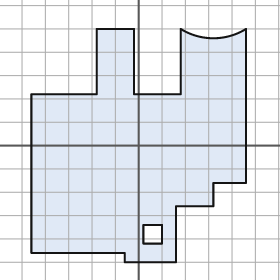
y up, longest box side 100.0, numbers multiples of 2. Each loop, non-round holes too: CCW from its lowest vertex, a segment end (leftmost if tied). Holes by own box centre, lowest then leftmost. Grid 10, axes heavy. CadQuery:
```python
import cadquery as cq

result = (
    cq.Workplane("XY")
    .moveTo(-6.0, -50.0)
    .lineTo(16.0, -50.0)
    .lineTo(16.0, -26.0)
    .lineTo(32.0, -26.0)
    .lineTo(32.0, -16.0)
    .lineTo(46.0, -16.0)
    .lineTo(46.0, 50.0)
    .threePointArc((32.0, 46.0), (18.0, 50.0))
    .lineTo(18.0, 22.0)
    .lineTo(-2.0, 22.0)
    .lineTo(-2.0, 50.0)
    .lineTo(-18.0, 50.0)
    .lineTo(-18.0, 22.0)
    .lineTo(-46.0, 22.0)
    .lineTo(-46.0, -46.0)
    .lineTo(-6.0, -46.0)
    .close()
    .moveTo(2.0, -42.0)
    .lineTo(10.0, -42.0)
    .lineTo(10.0, -34.0)
    .lineTo(2.0, -34.0)
    .close()
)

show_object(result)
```